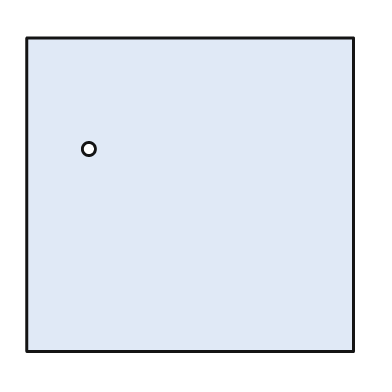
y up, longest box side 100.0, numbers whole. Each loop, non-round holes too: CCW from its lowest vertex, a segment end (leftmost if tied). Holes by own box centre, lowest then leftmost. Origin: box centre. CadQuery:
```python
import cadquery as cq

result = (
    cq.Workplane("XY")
    .moveTo(-50.0, -48.0)
    .lineTo(50.0, -48.0)
    .lineTo(50.0, 48.0)
    .lineTo(-50.0, 48.0)
    .close()
    .moveTo(-31.0, 14.0)
    .circle(2.0)
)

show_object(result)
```